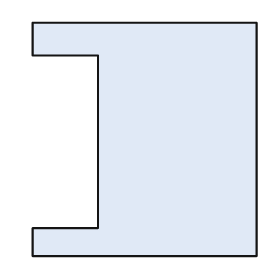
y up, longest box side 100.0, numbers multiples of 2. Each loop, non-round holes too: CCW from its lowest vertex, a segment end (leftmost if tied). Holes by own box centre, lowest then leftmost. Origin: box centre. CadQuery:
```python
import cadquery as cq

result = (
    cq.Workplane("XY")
    .moveTo(-48.0, -50.0)
    .lineTo(48.0, -50.0)
    .lineTo(48.0, 50.0)
    .lineTo(-48.0, 50.0)
    .lineTo(-48.0, 36.0)
    .lineTo(-20.0, 36.0)
    .lineTo(-20.0, -38.0)
    .lineTo(-48.0, -38.0)
    .close()
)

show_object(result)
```